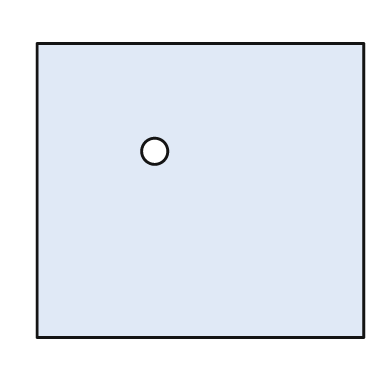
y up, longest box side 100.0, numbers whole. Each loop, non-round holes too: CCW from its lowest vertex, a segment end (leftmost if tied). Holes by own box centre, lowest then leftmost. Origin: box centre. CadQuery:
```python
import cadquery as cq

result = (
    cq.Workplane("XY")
    .moveTo(-50.0, -45.0)
    .lineTo(50.0, -45.0)
    .lineTo(50.0, 45.0)
    .lineTo(-50.0, 45.0)
    .close()
    .moveTo(-14.0, 12.0)
    .circle(4.0)
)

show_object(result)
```